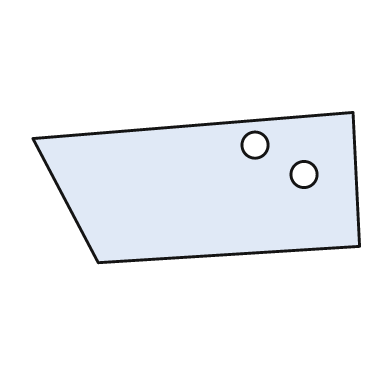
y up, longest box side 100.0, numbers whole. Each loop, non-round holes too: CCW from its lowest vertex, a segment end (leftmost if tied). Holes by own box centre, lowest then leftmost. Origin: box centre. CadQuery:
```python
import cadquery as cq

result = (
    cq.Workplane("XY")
    .moveTo(-30.0, -23.0)
    .lineTo(50.0, -18.0)
    .lineTo(48.0, 23.0)
    .lineTo(-50.0, 15.0)
    .close()
    .moveTo(33.0, 4.0)
    .circle(4.0)
    .moveTo(18.0, 13.0)
    .circle(4.0)
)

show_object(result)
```